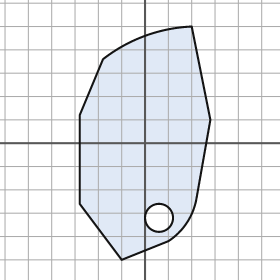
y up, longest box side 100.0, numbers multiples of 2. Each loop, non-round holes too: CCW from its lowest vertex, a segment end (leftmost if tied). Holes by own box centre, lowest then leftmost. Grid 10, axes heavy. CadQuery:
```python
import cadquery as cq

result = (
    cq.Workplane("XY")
    .moveTo(-10.0, -50.0)
    .lineTo(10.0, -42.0)
    .threePointArc((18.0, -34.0), (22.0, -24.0))
    .lineTo(28.0, 10.0)
    .lineTo(20.0, 50.0)
    .threePointArc((0.0, 46.0), (-18.0, 36.0))
    .lineTo(-28.0, 12.0)
    .lineTo(-28.0, -26.0)
    .close()
    .moveTo(6.0, -32.0)
    .circle(6.0)
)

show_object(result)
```